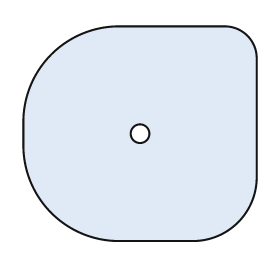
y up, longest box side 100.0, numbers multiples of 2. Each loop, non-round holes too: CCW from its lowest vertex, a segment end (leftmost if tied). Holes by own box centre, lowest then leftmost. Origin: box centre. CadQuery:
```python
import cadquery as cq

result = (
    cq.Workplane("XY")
    .moveTo(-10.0, -46.0)
    .lineTo(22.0, -46.0)
    .threePointArc((42.0, -38.0), (50.0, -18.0))
    .lineTo(50.0, 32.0)
    .threePointArc((46.0, 42.0), (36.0, 46.0))
    .lineTo(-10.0, 46.0)
    .threePointArc((-38.0, 34.0), (-50.0, 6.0))
    .lineTo(-50.0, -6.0)
    .threePointArc((-38.0, -34.0), (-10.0, -46.0))
    .close()
    .moveTo(0.0, 0.0)
    .circle(4.0)
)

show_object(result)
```